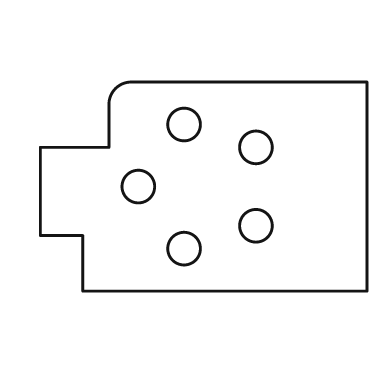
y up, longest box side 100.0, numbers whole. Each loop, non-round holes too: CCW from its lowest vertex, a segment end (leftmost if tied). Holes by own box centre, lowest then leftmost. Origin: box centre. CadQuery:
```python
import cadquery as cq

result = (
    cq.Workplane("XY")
    .moveTo(-37.0, -32.0)
    .lineTo(50.0, -32.0)
    .lineTo(50.0, 32.0)
    .lineTo(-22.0, 32.0)
    .threePointArc((-27.0, 30.0), (-29.0, 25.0))
    .lineTo(-29.0, 12.0)
    .lineTo(-50.0, 12.0)
    .lineTo(-50.0, -15.0)
    .lineTo(-37.0, -15.0)
    .close()
    .moveTo(-6.0, -19.0)
    .circle(5.0)
    .moveTo(16.0, -12.0)
    .circle(5.0)
    .moveTo(-20.0, 0.0)
    .circle(5.0)
    .moveTo(16.0, 12.0)
    .circle(5.0)
    .moveTo(-6.0, 19.0)
    .circle(5.0)
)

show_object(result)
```